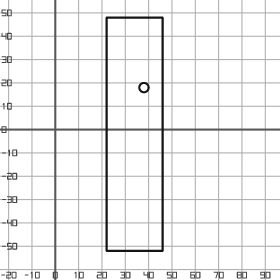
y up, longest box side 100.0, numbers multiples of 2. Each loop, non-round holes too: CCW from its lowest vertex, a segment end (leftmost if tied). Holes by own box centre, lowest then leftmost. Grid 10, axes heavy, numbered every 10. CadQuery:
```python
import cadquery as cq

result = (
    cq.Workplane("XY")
    .moveTo(22.0, -52.0)
    .lineTo(46.0, -52.0)
    .lineTo(46.0, 48.0)
    .lineTo(22.0, 48.0)
    .close()
    .moveTo(38.0, 18.0)
    .circle(2.0)
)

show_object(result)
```